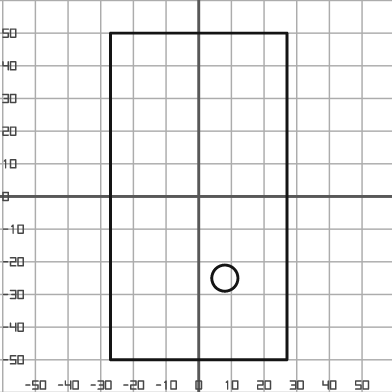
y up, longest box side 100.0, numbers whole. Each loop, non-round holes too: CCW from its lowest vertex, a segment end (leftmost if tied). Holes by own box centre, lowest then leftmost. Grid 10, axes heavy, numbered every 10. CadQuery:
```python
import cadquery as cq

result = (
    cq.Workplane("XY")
    .moveTo(-27.0, -50.0)
    .lineTo(27.0, -50.0)
    .lineTo(27.0, 50.0)
    .lineTo(-27.0, 50.0)
    .close()
    .moveTo(8.0, -25.0)
    .circle(4.0)
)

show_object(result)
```